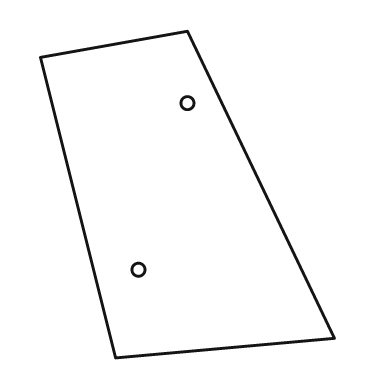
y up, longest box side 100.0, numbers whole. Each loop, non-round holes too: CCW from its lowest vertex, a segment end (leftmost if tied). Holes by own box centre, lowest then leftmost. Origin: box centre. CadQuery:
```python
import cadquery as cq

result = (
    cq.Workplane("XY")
    .moveTo(-22.0, -50.0)
    .lineTo(45.0, -44.0)
    .lineTo(0.0, 50.0)
    .lineTo(-45.0, 42.0)
    .close()
    .moveTo(-15.0, -23.0)
    .circle(2.0)
    .moveTo(0.0, 28.0)
    .circle(2.0)
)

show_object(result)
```